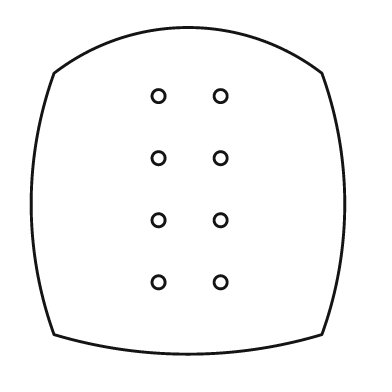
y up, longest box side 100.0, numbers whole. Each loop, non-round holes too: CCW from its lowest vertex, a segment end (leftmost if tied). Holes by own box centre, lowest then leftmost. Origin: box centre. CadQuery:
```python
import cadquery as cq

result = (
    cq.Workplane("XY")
    .moveTo(-41.0, -44.0)
    .threePointArc((0.0, -50.0), (41.0, -44.0))
    .threePointArc((48.0, -4.0), (41.0, 36.0))
    .threePointArc((0.0, 50.0), (-41.0, 36.0))
    .threePointArc((-48.0, -4.0), (-41.0, -44.0))
    .close()
    .moveTo(-9.0, -28.0)
    .circle(2.0)
    .moveTo(10.0, -28.0)
    .circle(2.0)
    .moveTo(-9.0, -9.0)
    .circle(2.0)
    .moveTo(10.0, -9.0)
    .circle(2.0)
    .moveTo(-9.0, 10.0)
    .circle(2.0)
    .moveTo(10.0, 10.0)
    .circle(2.0)
    .moveTo(-9.0, 29.0)
    .circle(2.0)
    .moveTo(10.0, 29.0)
    .circle(2.0)
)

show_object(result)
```